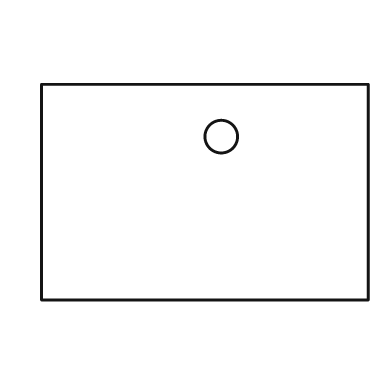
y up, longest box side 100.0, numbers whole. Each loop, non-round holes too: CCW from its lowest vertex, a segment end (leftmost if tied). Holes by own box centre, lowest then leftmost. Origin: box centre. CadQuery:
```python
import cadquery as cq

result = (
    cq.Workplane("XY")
    .moveTo(-50.0, -33.0)
    .lineTo(50.0, -33.0)
    .lineTo(50.0, 33.0)
    .lineTo(-50.0, 33.0)
    .close()
    .moveTo(5.0, 17.0)
    .circle(5.0)
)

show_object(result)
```